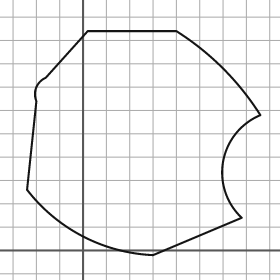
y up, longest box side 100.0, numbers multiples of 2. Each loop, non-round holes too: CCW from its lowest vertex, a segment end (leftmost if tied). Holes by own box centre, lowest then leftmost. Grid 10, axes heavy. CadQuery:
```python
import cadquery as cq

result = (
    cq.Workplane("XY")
    .moveTo(30.0, -2.0)
    .lineTo(68.0, 14.0)
    .threePointArc((60.0, 38.0), (76.0, 58.0))
    .threePointArc((60.0, 78.0), (40.0, 94.0))
    .lineTo(2.0, 94.0)
    .lineTo(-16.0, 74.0)
    .threePointArc((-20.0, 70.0), (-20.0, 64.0))
    .lineTo(-24.0, 26.0)
    .threePointArc((0.0, 6.0), (30.0, -2.0))
    .close()
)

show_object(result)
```